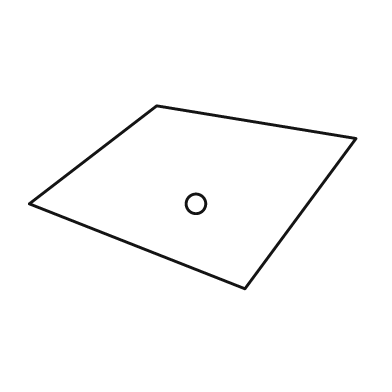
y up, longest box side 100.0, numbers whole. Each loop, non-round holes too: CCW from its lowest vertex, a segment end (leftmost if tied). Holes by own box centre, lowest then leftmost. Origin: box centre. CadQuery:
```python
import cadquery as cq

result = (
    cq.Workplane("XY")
    .moveTo(16.0, -28.0)
    .lineTo(50.0, 18.0)
    .lineTo(-11.0, 28.0)
    .lineTo(-50.0, -2.0)
    .close()
    .moveTo(1.0, -2.0)
    .circle(3.0)
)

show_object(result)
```